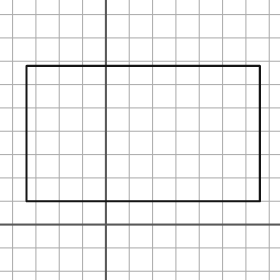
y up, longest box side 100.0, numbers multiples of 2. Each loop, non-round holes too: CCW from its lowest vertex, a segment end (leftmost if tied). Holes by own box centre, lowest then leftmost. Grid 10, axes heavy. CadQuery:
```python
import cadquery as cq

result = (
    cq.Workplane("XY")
    .moveTo(-34.0, 10.0)
    .lineTo(66.0, 10.0)
    .lineTo(66.0, 68.0)
    .lineTo(-34.0, 68.0)
    .close()
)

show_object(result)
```